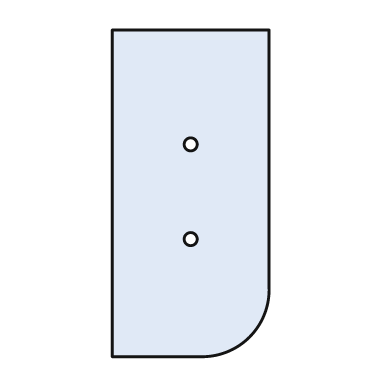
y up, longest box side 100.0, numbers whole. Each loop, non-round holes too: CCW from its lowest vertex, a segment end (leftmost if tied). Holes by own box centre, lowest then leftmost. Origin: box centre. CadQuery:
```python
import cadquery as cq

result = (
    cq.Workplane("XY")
    .moveTo(-24.0, -50.0)
    .lineTo(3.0, -50.0)
    .threePointArc((18.0, -44.0), (24.0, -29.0))
    .lineTo(24.0, 50.0)
    .lineTo(-24.0, 50.0)
    .close()
    .moveTo(0.0, -14.0)
    .circle(2.0)
    .moveTo(0.0, 15.0)
    .circle(2.0)
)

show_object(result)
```